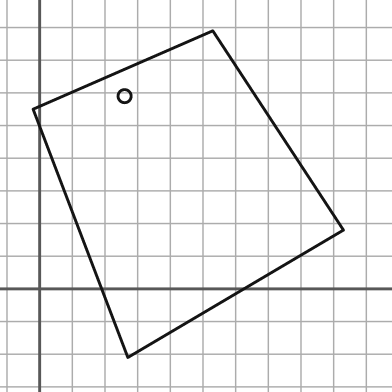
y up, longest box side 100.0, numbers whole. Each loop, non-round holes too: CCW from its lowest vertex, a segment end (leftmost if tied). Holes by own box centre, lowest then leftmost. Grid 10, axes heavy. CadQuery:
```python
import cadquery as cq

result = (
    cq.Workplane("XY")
    .moveTo(27.0, -21.0)
    .lineTo(93.0, 18.0)
    .lineTo(53.0, 79.0)
    .lineTo(-2.0, 55.0)
    .close()
    .moveTo(26.0, 59.0)
    .circle(2.0)
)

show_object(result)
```